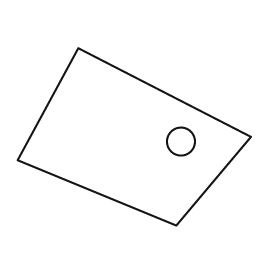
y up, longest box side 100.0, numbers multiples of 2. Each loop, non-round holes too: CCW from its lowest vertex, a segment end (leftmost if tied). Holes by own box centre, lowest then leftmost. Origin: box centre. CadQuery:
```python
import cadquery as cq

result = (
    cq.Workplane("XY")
    .moveTo(18.0, -38.0)
    .lineTo(50.0, 0.0)
    .lineTo(-24.0, 38.0)
    .lineTo(-50.0, -10.0)
    .close()
    .moveTo(20.0, -2.0)
    .circle(6.0)
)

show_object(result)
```